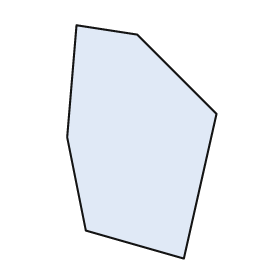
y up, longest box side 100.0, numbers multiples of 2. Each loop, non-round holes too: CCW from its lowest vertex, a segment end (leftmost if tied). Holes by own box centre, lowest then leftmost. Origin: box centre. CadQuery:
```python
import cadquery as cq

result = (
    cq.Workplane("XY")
    .moveTo(18.0, -50.0)
    .lineTo(32.0, 12.0)
    .lineTo(-2.0, 46.0)
    .lineTo(-28.0, 50.0)
    .lineTo(-32.0, 2.0)
    .lineTo(-24.0, -38.0)
    .close()
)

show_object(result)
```